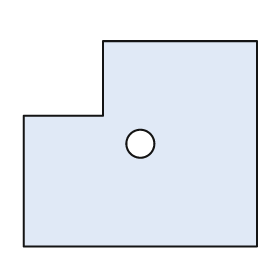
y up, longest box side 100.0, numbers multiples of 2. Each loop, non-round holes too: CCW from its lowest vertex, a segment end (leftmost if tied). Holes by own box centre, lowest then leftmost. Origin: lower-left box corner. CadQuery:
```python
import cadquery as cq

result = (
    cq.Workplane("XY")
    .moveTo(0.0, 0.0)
    .lineTo(100.0, 0.0)
    .lineTo(100.0, 88.0)
    .lineTo(34.0, 88.0)
    .lineTo(34.0, 56.0)
    .lineTo(0.0, 56.0)
    .close()
    .moveTo(50.0, 44.0)
    .circle(6.0)
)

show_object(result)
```